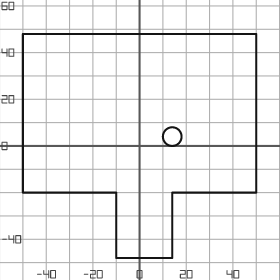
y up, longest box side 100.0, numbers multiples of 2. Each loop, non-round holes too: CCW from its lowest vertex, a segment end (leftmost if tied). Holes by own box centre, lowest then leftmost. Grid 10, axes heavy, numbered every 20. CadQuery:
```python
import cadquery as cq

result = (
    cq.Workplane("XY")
    .moveTo(-10.0, -48.0)
    .lineTo(14.0, -48.0)
    .lineTo(14.0, -20.0)
    .lineTo(50.0, -20.0)
    .lineTo(50.0, 48.0)
    .lineTo(-50.0, 48.0)
    .lineTo(-50.0, -20.0)
    .lineTo(-10.0, -20.0)
    .close()
    .moveTo(14.0, 4.0)
    .circle(4.0)
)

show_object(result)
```